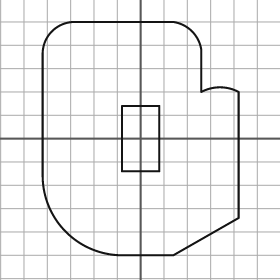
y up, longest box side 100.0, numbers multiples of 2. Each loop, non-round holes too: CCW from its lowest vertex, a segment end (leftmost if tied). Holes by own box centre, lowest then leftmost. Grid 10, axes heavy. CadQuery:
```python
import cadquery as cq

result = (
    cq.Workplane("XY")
    .moveTo(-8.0, -50.0)
    .lineTo(14.0, -50.0)
    .lineTo(42.0, -34.0)
    .lineTo(42.0, 20.0)
    .threePointArc((34.0, 22.0), (26.0, 20.0))
    .lineTo(26.0, 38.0)
    .threePointArc((22.0, 46.0), (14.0, 50.0))
    .lineTo(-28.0, 50.0)
    .threePointArc((-38.0, 46.0), (-42.0, 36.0))
    .lineTo(-42.0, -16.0)
    .threePointArc((-32.0, -40.0), (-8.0, -50.0))
    .close()
    .moveTo(-8.0, -14.0)
    .lineTo(8.0, -14.0)
    .lineTo(8.0, 14.0)
    .lineTo(-8.0, 14.0)
    .close()
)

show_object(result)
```